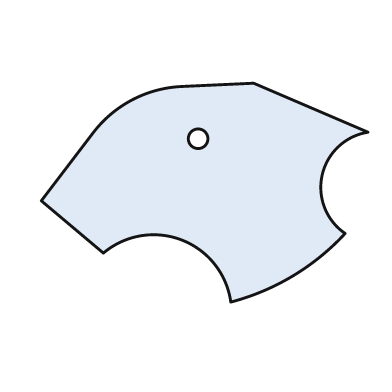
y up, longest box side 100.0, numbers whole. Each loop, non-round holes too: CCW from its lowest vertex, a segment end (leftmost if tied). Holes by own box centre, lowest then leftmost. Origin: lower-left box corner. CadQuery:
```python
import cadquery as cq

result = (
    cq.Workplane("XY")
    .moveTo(58.0, 0.0)
    .threePointArc((77.0, 8.0), (93.0, 21.0))
    .threePointArc((86.0, 39.0), (100.0, 52.0))
    .lineTo(65.0, 67.0)
    .lineTo(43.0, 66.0)
    .threePointArc((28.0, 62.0), (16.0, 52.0))
    .lineTo(0.0, 31.0)
    .lineTo(19.0, 15.0)
    .threePointArc((43.0, 19.0), (58.0, 0.0))
    .close()
    .moveTo(48.0, 50.0)
    .circle(3.0)
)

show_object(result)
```